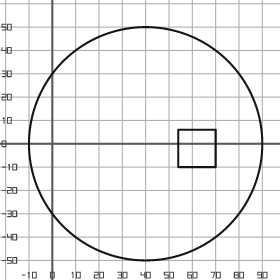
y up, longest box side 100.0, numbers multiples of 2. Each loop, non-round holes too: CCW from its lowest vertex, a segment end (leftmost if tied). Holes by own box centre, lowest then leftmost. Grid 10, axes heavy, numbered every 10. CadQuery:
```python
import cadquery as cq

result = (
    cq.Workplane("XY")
    .moveTo(40.0, 0.0)
    .circle(50.0)
    .moveTo(54.0, -10.0)
    .lineTo(70.0, -10.0)
    .lineTo(70.0, 6.0)
    .lineTo(54.0, 6.0)
    .close()
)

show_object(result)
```